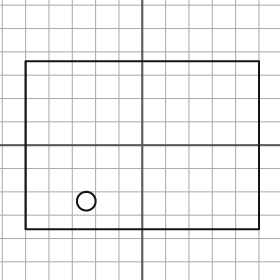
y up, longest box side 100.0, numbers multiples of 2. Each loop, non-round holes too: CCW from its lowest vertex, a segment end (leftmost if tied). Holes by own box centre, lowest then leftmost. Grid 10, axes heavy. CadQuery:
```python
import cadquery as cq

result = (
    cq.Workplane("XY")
    .moveTo(-50.0, -36.0)
    .lineTo(50.0, -36.0)
    .lineTo(50.0, 36.0)
    .lineTo(-50.0, 36.0)
    .close()
    .moveTo(-24.0, -24.0)
    .circle(4.0)
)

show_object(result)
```